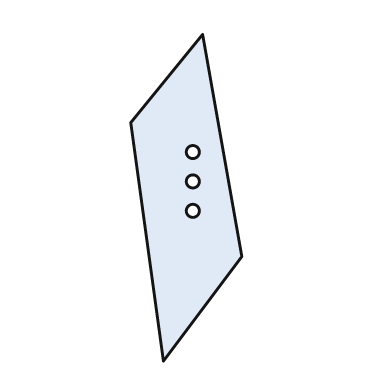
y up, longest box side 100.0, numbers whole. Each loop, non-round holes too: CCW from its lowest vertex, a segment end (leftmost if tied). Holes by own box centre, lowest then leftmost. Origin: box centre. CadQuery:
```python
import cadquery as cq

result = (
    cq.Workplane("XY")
    .moveTo(-7.0, -50.0)
    .lineTo(17.0, -18.0)
    .lineTo(5.0, 50.0)
    .lineTo(-17.0, 23.0)
    .close()
    .moveTo(2.0, -4.0)
    .circle(2.0)
    .moveTo(2.0, 5.0)
    .circle(2.0)
    .moveTo(2.0, 14.0)
    .circle(2.0)
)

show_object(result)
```